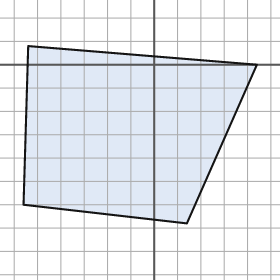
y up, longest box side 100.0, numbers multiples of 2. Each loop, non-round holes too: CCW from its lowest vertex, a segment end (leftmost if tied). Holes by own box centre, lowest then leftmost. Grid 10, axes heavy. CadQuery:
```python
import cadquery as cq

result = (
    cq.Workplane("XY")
    .moveTo(14.0, -68.0)
    .lineTo(44.0, 0.0)
    .lineTo(-54.0, 8.0)
    .lineTo(-56.0, -60.0)
    .close()
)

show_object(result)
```